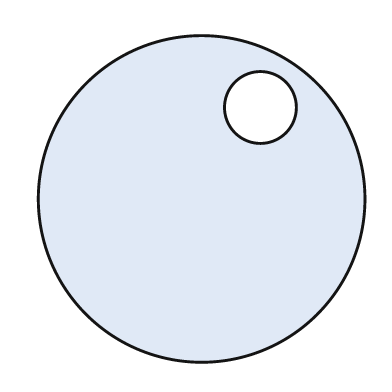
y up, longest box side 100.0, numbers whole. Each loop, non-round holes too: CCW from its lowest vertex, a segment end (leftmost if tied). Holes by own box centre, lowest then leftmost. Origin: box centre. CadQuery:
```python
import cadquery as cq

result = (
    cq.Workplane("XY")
    .moveTo(0.0, 0.0)
    .circle(50.0)
    .moveTo(18.0, 28.0)
    .circle(11.0)
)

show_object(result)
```